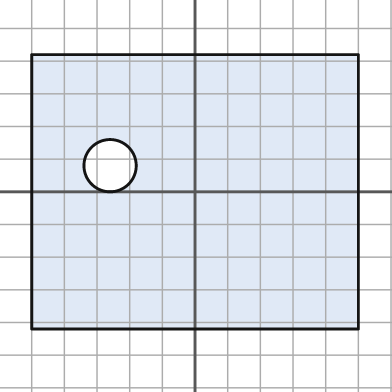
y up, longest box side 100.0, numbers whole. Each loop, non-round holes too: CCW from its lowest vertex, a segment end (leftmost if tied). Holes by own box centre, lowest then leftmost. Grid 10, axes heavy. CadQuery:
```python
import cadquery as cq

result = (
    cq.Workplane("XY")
    .moveTo(-50.0, -42.0)
    .lineTo(50.0, -42.0)
    .lineTo(50.0, 42.0)
    .lineTo(-50.0, 42.0)
    .close()
    .moveTo(-26.0, 8.0)
    .circle(8.0)
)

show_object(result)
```